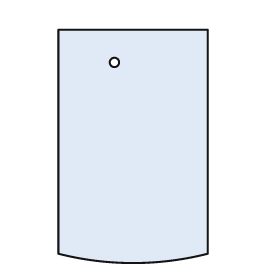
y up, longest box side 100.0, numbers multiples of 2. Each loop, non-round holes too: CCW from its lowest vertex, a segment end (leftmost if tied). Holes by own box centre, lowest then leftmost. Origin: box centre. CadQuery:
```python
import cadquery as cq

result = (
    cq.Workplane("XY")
    .moveTo(-32.0, -46.0)
    .threePointArc((0.0, -50.0), (32.0, -46.0))
    .lineTo(32.0, 50.0)
    .lineTo(-32.0, 50.0)
    .close()
    .moveTo(-8.0, 36.0)
    .circle(2.0)
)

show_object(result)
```